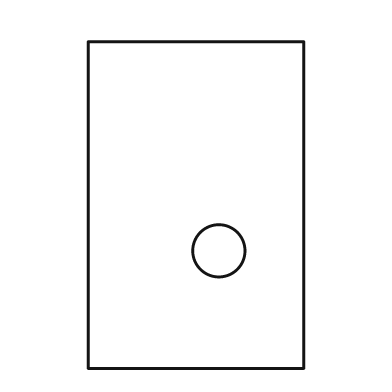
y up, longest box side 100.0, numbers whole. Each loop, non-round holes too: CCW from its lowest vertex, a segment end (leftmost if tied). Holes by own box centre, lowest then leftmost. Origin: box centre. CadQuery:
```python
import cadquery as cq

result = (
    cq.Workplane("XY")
    .moveTo(-33.0, -50.0)
    .lineTo(33.0, -50.0)
    .lineTo(33.0, 50.0)
    .lineTo(-33.0, 50.0)
    .close()
    .moveTo(7.0, -14.0)
    .circle(8.0)
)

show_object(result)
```